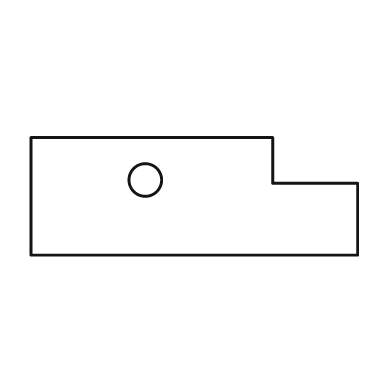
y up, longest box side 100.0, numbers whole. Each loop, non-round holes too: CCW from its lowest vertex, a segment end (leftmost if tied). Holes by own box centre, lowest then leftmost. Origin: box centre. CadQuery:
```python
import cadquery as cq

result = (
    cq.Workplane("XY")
    .moveTo(-50.0, -18.0)
    .lineTo(50.0, -18.0)
    .lineTo(50.0, 4.0)
    .lineTo(24.0, 4.0)
    .lineTo(24.0, 18.0)
    .lineTo(-50.0, 18.0)
    .close()
    .moveTo(-15.0, 5.0)
    .circle(5.0)
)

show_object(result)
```